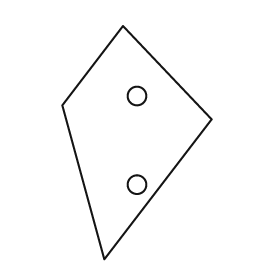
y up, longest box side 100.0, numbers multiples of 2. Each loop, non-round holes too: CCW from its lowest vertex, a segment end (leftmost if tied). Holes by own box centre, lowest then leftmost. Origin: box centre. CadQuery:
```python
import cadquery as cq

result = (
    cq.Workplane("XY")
    .moveTo(-14.0, -50.0)
    .lineTo(32.0, 10.0)
    .lineTo(-6.0, 50.0)
    .lineTo(-32.0, 16.0)
    .close()
    .moveTo(0.0, -18.0)
    .circle(4.0)
    .moveTo(0.0, 20.0)
    .circle(4.0)
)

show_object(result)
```